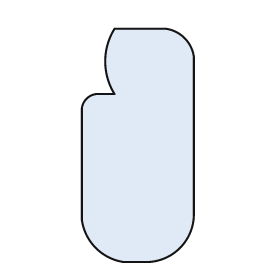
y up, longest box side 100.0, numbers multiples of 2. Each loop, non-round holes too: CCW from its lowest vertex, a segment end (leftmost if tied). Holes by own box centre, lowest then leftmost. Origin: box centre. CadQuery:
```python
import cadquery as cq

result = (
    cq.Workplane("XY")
    .moveTo(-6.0, -50.0)
    .lineTo(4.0, -50.0)
    .threePointArc((18.0, -44.0), (24.0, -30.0))
    .lineTo(24.0, 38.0)
    .threePointArc((20.0, 46.0), (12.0, 50.0))
    .lineTo(-10.0, 50.0)
    .threePointArc((-14.0, 36.0), (-10.0, 22.0))
    .lineTo(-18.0, 22.0)
    .threePointArc((-22.0, 20.0), (-24.0, 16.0))
    .lineTo(-24.0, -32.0)
    .threePointArc((-18.0, -44.0), (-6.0, -50.0))
    .close()
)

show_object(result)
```